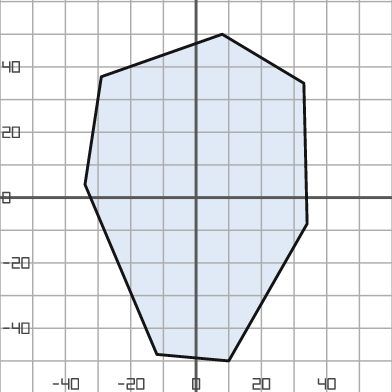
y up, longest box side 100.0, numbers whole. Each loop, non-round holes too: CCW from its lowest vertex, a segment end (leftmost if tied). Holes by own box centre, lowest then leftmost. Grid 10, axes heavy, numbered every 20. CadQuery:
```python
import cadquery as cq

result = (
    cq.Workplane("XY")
    .moveTo(10.0, -50.0)
    .lineTo(34.0, -8.0)
    .lineTo(33.0, 35.0)
    .lineTo(8.0, 50.0)
    .lineTo(-29.0, 37.0)
    .lineTo(-34.0, 4.0)
    .lineTo(-12.0, -48.0)
    .close()
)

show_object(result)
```